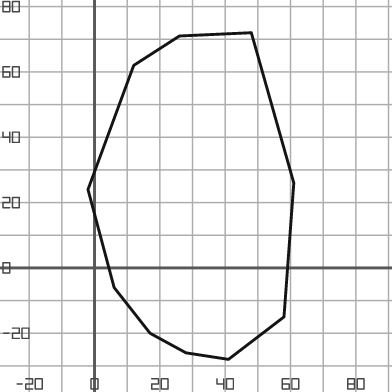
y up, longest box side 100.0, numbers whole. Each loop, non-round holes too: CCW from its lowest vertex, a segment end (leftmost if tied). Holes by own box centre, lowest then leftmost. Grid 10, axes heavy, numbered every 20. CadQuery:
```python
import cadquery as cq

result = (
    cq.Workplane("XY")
    .moveTo(41.0, -28.0)
    .lineTo(58.0, -15.0)
    .lineTo(61.0, 26.0)
    .lineTo(48.0, 72.0)
    .lineTo(26.0, 71.0)
    .lineTo(12.0, 62.0)
    .lineTo(-2.0, 24.0)
    .lineTo(6.0, -6.0)
    .lineTo(17.0, -20.0)
    .lineTo(28.0, -26.0)
    .close()
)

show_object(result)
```